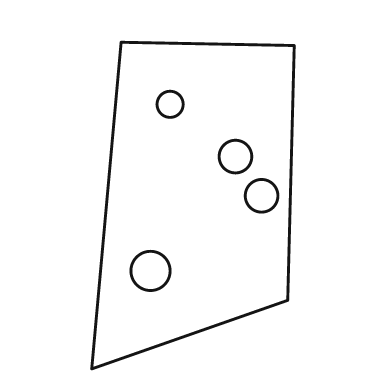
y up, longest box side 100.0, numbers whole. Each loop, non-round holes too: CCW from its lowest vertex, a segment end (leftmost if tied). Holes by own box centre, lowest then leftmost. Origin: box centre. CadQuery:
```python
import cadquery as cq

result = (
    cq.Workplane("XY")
    .moveTo(-31.0, -50.0)
    .lineTo(29.0, -29.0)
    .lineTo(31.0, 49.0)
    .lineTo(-22.0, 50.0)
    .close()
    .moveTo(-13.0, -20.0)
    .circle(6.0)
    .moveTo(21.0, 3.0)
    .circle(5.0)
    .moveTo(13.0, 15.0)
    .circle(5.0)
    .moveTo(-7.0, 31.0)
    .circle(4.0)
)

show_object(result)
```